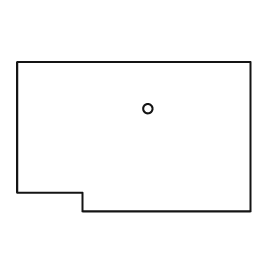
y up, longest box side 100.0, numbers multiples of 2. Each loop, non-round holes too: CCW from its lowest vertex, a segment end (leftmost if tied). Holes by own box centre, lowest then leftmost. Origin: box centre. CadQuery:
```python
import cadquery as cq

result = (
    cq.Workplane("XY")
    .moveTo(-22.0, -32.0)
    .lineTo(50.0, -32.0)
    .lineTo(50.0, 32.0)
    .lineTo(-50.0, 32.0)
    .lineTo(-50.0, -24.0)
    .lineTo(-22.0, -24.0)
    .close()
    .moveTo(6.0, 12.0)
    .circle(2.0)
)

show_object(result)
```